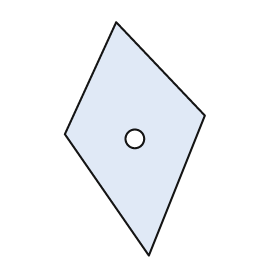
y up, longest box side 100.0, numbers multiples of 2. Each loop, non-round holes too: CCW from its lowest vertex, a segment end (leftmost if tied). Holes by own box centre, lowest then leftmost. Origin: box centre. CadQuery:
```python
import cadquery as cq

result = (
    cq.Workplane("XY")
    .moveTo(6.0, -50.0)
    .lineTo(30.0, 10.0)
    .lineTo(-8.0, 50.0)
    .lineTo(-30.0, 2.0)
    .close()
    .moveTo(0.0, 0.0)
    .circle(4.0)
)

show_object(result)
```